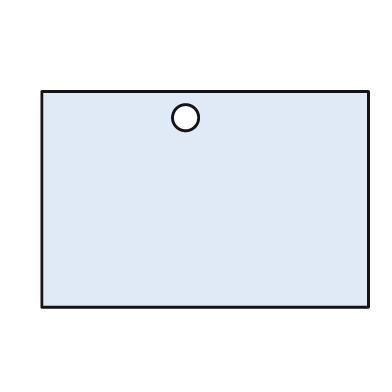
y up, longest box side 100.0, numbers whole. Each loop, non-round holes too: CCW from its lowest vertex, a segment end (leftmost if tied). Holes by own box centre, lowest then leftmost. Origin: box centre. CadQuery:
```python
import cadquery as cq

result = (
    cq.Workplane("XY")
    .moveTo(-50.0, -33.0)
    .lineTo(50.0, -33.0)
    .lineTo(50.0, 33.0)
    .lineTo(-50.0, 33.0)
    .close()
    .moveTo(-6.0, 25.0)
    .circle(4.0)
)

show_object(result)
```